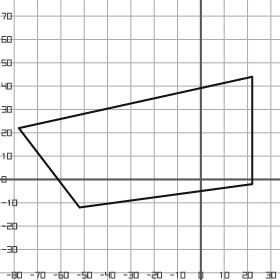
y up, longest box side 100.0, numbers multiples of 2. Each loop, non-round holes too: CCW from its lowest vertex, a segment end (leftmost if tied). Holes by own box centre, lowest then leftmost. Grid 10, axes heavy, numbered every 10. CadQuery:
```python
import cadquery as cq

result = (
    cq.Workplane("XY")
    .moveTo(-52.0, -12.0)
    .lineTo(22.0, -2.0)
    .lineTo(22.0, 44.0)
    .lineTo(-78.0, 22.0)
    .close()
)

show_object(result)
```